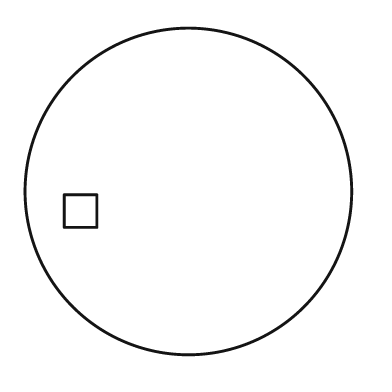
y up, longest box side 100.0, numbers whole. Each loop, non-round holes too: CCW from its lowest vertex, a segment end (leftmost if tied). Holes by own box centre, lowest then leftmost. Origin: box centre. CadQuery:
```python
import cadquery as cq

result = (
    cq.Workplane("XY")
    .moveTo(0.0, 0.0)
    .circle(50.0)
    .moveTo(-38.0, -11.0)
    .lineTo(-28.0, -11.0)
    .lineTo(-28.0, -1.0)
    .lineTo(-38.0, -1.0)
    .close()
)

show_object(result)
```